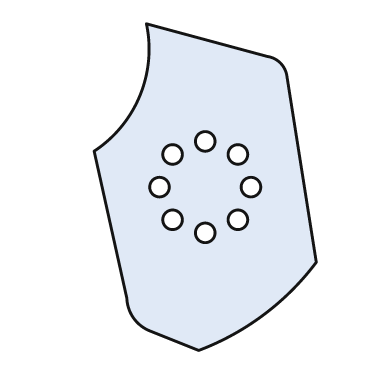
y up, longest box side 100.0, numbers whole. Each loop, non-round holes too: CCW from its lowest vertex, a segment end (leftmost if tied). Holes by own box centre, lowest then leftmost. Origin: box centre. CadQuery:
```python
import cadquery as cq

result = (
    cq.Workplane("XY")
    .moveTo(-2.0, -50.0)
    .threePointArc((18.0, -39.0), (34.0, -23.0))
    .lineTo(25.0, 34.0)
    .threePointArc((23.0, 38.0), (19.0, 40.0))
    .lineTo(-18.0, 50.0)
    .threePointArc((-20.0, 28.0), (-34.0, 11.0))
    .lineTo(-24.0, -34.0)
    .threePointArc((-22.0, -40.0), (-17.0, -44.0))
    .close()
    .moveTo(0.0, -14.0)
    .circle(3.0)
    .moveTo(-10.0, -10.0)
    .circle(3.0)
    .moveTo(10.0, -10.0)
    .circle(3.0)
    .moveTo(-14.0, 0.0)
    .circle(3.0)
    .moveTo(14.0, 0.0)
    .circle(3.0)
    .moveTo(-10.0, 10.0)
    .circle(3.0)
    .moveTo(10.0, 10.0)
    .circle(3.0)
    .moveTo(0.0, 14.0)
    .circle(3.0)
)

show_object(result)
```